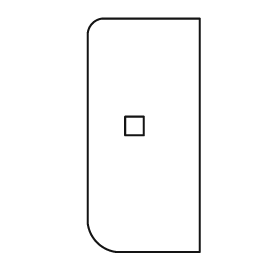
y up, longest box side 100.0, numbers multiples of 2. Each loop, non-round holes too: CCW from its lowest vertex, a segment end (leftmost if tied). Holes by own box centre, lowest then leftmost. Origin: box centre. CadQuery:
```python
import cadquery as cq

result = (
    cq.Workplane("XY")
    .moveTo(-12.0, -50.0)
    .lineTo(24.0, -50.0)
    .lineTo(24.0, 50.0)
    .lineTo(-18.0, 50.0)
    .threePointArc((-22.0, 48.0), (-24.0, 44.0))
    .lineTo(-24.0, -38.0)
    .threePointArc((-20.0, -46.0), (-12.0, -50.0))
    .close()
    .moveTo(-8.0, 0.0)
    .lineTo(0.0, 0.0)
    .lineTo(0.0, 8.0)
    .lineTo(-8.0, 8.0)
    .close()
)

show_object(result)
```